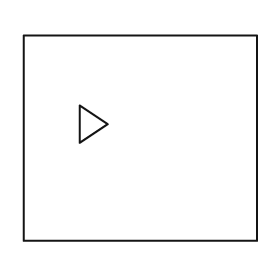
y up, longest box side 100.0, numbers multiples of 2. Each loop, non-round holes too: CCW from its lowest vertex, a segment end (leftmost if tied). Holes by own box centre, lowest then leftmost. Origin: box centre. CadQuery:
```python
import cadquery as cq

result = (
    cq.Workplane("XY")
    .moveTo(-50.0, -44.0)
    .lineTo(50.0, -44.0)
    .lineTo(50.0, 44.0)
    .lineTo(-50.0, 44.0)
    .close()
    .moveTo(-26.0, -2.0)
    .lineTo(-14.0, 6.0)
    .lineTo(-26.0, 14.0)
    .close()
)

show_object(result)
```